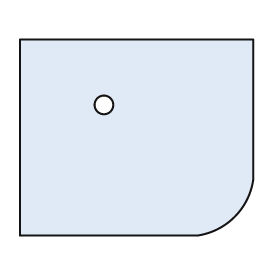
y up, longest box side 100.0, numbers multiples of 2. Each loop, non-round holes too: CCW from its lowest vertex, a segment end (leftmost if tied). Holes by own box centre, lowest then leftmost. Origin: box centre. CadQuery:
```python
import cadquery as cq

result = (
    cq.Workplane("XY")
    .moveTo(-50.0, -42.0)
    .lineTo(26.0, -42.0)
    .threePointArc((42.0, -34.0), (50.0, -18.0))
    .lineTo(50.0, 42.0)
    .lineTo(-50.0, 42.0)
    .close()
    .moveTo(-14.0, 14.0)
    .circle(4.0)
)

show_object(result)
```